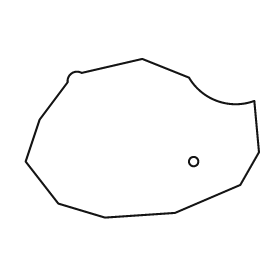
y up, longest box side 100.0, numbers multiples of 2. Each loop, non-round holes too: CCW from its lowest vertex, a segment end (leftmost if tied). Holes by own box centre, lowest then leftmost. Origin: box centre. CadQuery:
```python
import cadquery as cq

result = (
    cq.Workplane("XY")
    .moveTo(-16.0, -34.0)
    .lineTo(14.0, -32.0)
    .lineTo(42.0, -20.0)
    .lineTo(50.0, -6.0)
    .lineTo(48.0, 16.0)
    .threePointArc((32.0, 16.0), (20.0, 26.0))
    .lineTo(0.0, 34.0)
    .lineTo(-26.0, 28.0)
    .threePointArc((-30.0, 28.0), (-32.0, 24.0))
    .lineTo(-44.0, 8.0)
    .lineTo(-50.0, -10.0)
    .lineTo(-36.0, -28.0)
    .close()
    .moveTo(22.0, -10.0)
    .circle(2.0)
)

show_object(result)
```